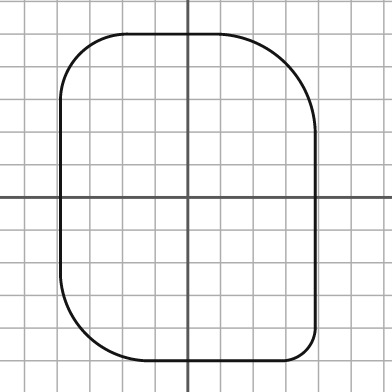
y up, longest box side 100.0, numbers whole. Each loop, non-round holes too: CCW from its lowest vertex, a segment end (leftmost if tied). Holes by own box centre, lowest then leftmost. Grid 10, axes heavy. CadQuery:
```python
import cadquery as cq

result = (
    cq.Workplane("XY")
    .moveTo(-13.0, -50.0)
    .lineTo(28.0, -50.0)
    .threePointArc((36.0, -47.0), (39.0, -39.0))
    .lineTo(39.0, 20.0)
    .threePointArc((30.0, 41.0), (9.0, 50.0))
    .lineTo(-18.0, 50.0)
    .threePointArc((-33.0, 44.0), (-39.0, 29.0))
    .lineTo(-39.0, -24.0)
    .threePointArc((-31.0, -42.0), (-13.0, -50.0))
    .close()
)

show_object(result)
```